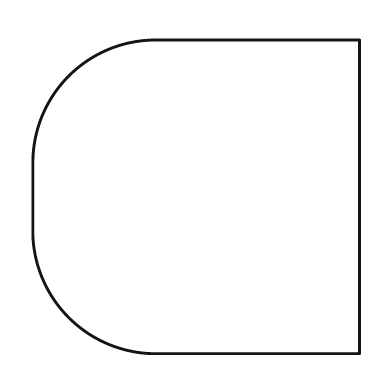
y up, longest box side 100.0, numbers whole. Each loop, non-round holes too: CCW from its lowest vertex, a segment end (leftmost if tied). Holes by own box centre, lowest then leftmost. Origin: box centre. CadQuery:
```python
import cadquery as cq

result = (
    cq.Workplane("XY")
    .moveTo(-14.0, -48.0)
    .lineTo(50.0, -48.0)
    .lineTo(50.0, 48.0)
    .lineTo(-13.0, 48.0)
    .threePointArc((-39.0, 37.0), (-50.0, 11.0))
    .lineTo(-50.0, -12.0)
    .threePointArc((-39.0, -37.0), (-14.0, -48.0))
    .close()
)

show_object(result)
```